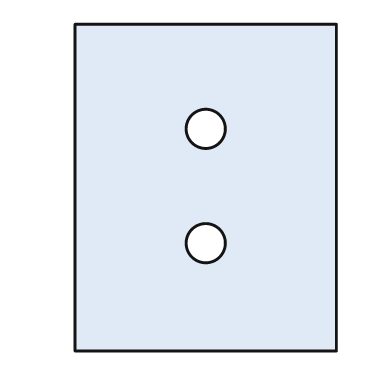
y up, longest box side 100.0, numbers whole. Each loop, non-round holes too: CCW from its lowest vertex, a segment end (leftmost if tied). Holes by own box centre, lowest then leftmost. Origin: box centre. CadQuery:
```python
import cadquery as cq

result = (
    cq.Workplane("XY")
    .moveTo(-40.0, -50.0)
    .lineTo(40.0, -50.0)
    .lineTo(40.0, 50.0)
    .lineTo(-40.0, 50.0)
    .close()
    .moveTo(0.0, -17.0)
    .circle(6.0)
    .moveTo(0.0, 18.0)
    .circle(6.0)
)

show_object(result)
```